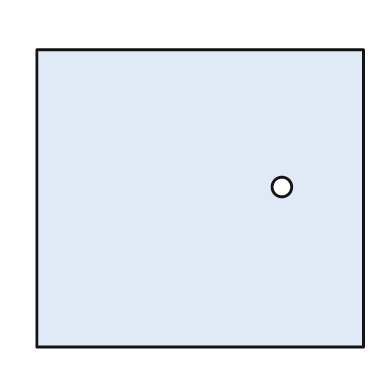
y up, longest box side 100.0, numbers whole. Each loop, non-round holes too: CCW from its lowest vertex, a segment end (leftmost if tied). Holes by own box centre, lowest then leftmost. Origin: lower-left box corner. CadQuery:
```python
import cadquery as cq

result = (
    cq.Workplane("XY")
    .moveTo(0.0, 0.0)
    .lineTo(100.0, 0.0)
    .lineTo(100.0, 91.0)
    .lineTo(0.0, 91.0)
    .close()
    .moveTo(75.0, 49.0)
    .circle(3.0)
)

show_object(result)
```